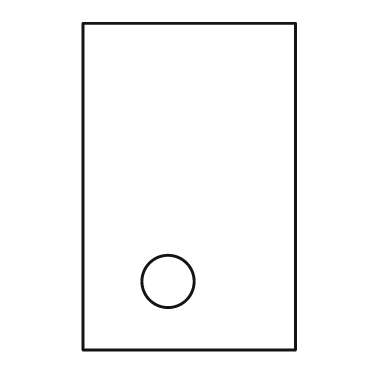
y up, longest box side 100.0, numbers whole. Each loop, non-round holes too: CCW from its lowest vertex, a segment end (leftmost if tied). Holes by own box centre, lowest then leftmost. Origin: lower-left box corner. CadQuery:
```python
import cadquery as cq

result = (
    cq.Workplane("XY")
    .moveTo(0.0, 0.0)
    .lineTo(65.0, 0.0)
    .lineTo(65.0, 100.0)
    .lineTo(0.0, 100.0)
    .close()
    .moveTo(26.0, 21.0)
    .circle(8.0)
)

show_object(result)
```